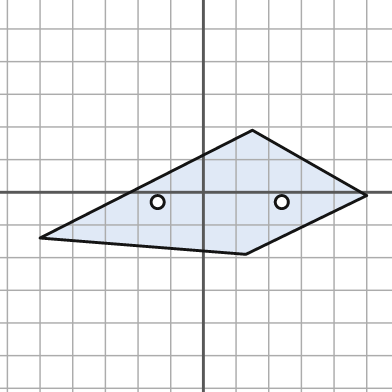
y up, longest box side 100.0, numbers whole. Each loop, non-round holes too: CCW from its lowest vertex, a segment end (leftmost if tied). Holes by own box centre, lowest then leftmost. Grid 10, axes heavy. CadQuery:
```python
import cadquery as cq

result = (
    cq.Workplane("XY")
    .moveTo(13.0, -19.0)
    .lineTo(50.0, -1.0)
    .lineTo(15.0, 19.0)
    .lineTo(-50.0, -14.0)
    .close()
    .moveTo(-14.0, -3.0)
    .circle(2.0)
    .moveTo(24.0, -3.0)
    .circle(2.0)
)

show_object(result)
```